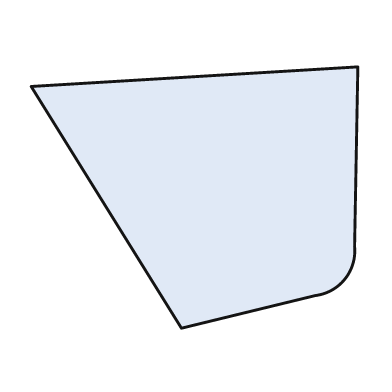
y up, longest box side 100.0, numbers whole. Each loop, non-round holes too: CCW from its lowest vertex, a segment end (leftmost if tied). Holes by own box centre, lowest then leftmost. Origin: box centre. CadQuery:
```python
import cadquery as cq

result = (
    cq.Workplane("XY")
    .moveTo(-4.0, -40.0)
    .lineTo(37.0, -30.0)
    .threePointArc((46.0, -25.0), (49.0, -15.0))
    .lineTo(50.0, 40.0)
    .lineTo(-50.0, 34.0)
    .close()
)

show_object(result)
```